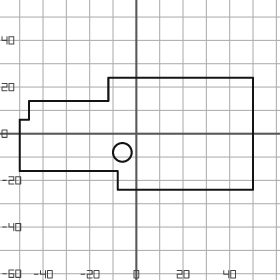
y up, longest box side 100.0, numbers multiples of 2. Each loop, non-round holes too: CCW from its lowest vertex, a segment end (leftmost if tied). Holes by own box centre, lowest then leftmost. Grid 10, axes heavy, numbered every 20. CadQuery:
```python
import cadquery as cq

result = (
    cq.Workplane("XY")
    .moveTo(-8.0, -24.0)
    .lineTo(50.0, -24.0)
    .lineTo(50.0, 24.0)
    .lineTo(-12.0, 24.0)
    .lineTo(-12.0, 14.0)
    .lineTo(-46.0, 14.0)
    .lineTo(-46.0, 6.0)
    .lineTo(-50.0, 6.0)
    .lineTo(-50.0, -16.0)
    .lineTo(-8.0, -16.0)
    .close()
    .moveTo(-6.0, -8.0)
    .circle(4.0)
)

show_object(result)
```